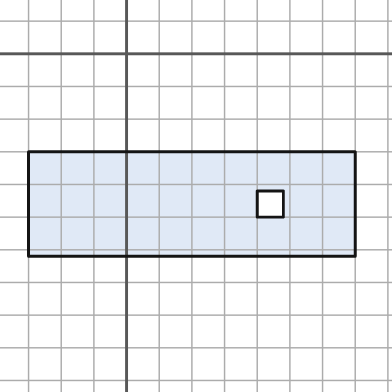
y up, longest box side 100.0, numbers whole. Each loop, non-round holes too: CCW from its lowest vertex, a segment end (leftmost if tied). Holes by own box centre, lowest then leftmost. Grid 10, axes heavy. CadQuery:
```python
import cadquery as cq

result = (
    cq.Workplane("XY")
    .moveTo(-30.0, -62.0)
    .lineTo(70.0, -62.0)
    .lineTo(70.0, -30.0)
    .lineTo(-30.0, -30.0)
    .close()
    .moveTo(40.0, -50.0)
    .lineTo(48.0, -50.0)
    .lineTo(48.0, -42.0)
    .lineTo(40.0, -42.0)
    .close()
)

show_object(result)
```